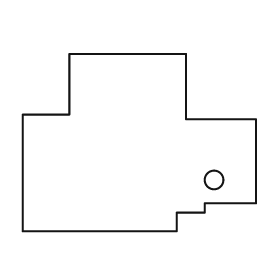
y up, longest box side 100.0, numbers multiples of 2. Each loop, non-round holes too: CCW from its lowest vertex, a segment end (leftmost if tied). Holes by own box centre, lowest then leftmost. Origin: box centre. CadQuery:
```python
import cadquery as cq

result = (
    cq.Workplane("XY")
    .moveTo(-50.0, -38.0)
    .lineTo(16.0, -38.0)
    .lineTo(16.0, -30.0)
    .lineTo(28.0, -30.0)
    .lineTo(28.0, -26.0)
    .lineTo(50.0, -26.0)
    .lineTo(50.0, 10.0)
    .lineTo(20.0, 10.0)
    .lineTo(20.0, 38.0)
    .lineTo(-30.0, 38.0)
    .lineTo(-30.0, 12.0)
    .lineTo(-50.0, 12.0)
    .close()
    .moveTo(32.0, -16.0)
    .circle(4.0)
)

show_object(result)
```